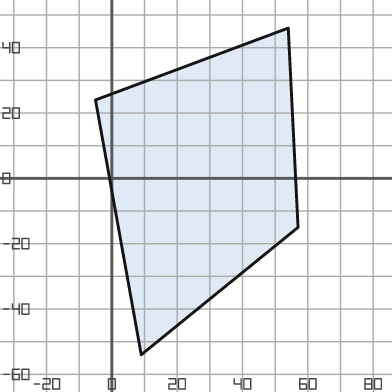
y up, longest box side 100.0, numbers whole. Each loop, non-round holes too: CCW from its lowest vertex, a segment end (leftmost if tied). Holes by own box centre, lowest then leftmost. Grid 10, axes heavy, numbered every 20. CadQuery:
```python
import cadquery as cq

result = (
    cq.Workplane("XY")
    .moveTo(9.0, -54.0)
    .lineTo(57.0, -15.0)
    .lineTo(54.0, 46.0)
    .lineTo(-5.0, 24.0)
    .close()
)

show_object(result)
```